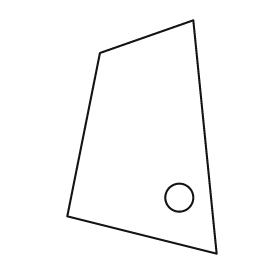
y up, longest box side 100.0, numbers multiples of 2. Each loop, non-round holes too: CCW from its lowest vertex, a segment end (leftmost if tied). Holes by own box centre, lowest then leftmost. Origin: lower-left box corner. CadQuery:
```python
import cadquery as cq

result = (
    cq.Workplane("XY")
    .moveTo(64.0, 0.0)
    .lineTo(54.0, 100.0)
    .lineTo(14.0, 86.0)
    .lineTo(0.0, 16.0)
    .close()
    .moveTo(48.0, 24.0)
    .circle(6.0)
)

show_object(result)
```